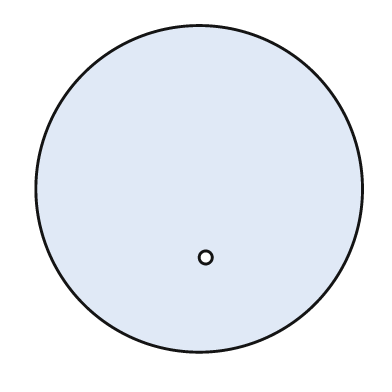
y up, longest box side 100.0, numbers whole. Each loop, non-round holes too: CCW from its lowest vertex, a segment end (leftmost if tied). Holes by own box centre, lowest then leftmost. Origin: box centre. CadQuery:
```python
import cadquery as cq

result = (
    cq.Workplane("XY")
    .moveTo(0.0, 0.0)
    .circle(50.0)
    .moveTo(2.0, -21.0)
    .circle(2.0)
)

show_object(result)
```